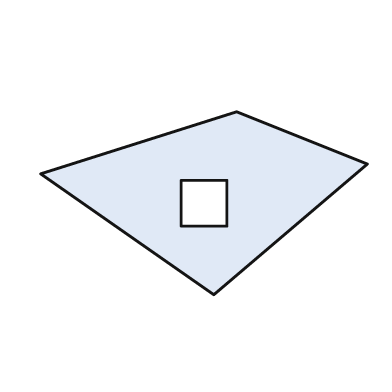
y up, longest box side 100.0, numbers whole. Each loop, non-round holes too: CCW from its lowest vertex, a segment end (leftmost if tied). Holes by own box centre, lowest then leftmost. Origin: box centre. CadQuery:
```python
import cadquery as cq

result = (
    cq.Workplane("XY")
    .moveTo(3.0, -28.0)
    .lineTo(50.0, 12.0)
    .lineTo(10.0, 28.0)
    .lineTo(-50.0, 9.0)
    .close()
    .moveTo(-7.0, -7.0)
    .lineTo(7.0, -7.0)
    .lineTo(7.0, 7.0)
    .lineTo(-7.0, 7.0)
    .close()
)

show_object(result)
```